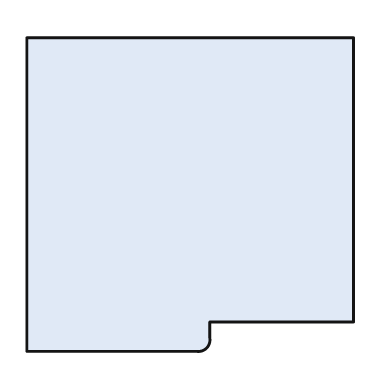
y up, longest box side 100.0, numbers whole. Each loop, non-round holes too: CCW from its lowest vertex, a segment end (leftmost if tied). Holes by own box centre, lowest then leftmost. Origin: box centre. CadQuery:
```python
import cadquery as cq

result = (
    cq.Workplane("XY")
    .moveTo(-50.0, -48.0)
    .lineTo(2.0, -48.0)
    .threePointArc((5.0, -47.0), (6.0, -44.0))
    .lineTo(6.0, -39.0)
    .lineTo(50.0, -39.0)
    .lineTo(50.0, 48.0)
    .lineTo(-50.0, 48.0)
    .close()
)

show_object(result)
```